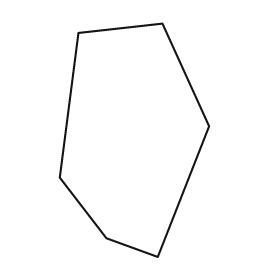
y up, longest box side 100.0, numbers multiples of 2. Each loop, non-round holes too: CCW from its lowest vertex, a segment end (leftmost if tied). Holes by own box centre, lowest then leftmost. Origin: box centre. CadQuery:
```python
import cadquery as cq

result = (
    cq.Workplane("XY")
    .moveTo(10.0, -50.0)
    .lineTo(32.0, 6.0)
    .lineTo(12.0, 50.0)
    .lineTo(-24.0, 46.0)
    .lineTo(-32.0, -16.0)
    .lineTo(-12.0, -42.0)
    .close()
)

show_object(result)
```